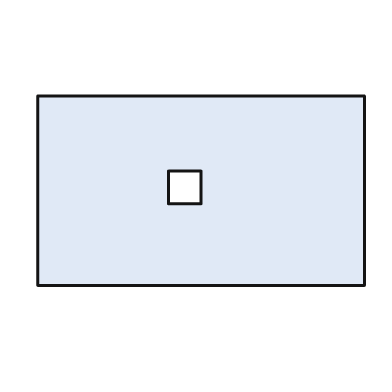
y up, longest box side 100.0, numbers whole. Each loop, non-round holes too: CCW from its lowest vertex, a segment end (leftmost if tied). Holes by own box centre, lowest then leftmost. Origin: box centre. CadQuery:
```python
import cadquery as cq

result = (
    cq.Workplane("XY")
    .moveTo(-50.0, -29.0)
    .lineTo(50.0, -29.0)
    .lineTo(50.0, 29.0)
    .lineTo(-50.0, 29.0)
    .close()
    .moveTo(-10.0, -4.0)
    .lineTo(0.0, -4.0)
    .lineTo(0.0, 6.0)
    .lineTo(-10.0, 6.0)
    .close()
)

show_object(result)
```